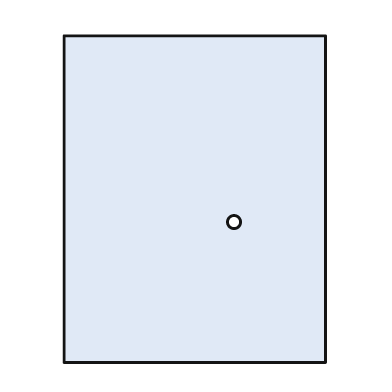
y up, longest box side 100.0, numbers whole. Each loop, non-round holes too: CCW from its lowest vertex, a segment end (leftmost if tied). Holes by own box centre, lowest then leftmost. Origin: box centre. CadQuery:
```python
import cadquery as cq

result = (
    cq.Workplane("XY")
    .moveTo(-40.0, -50.0)
    .lineTo(40.0, -50.0)
    .lineTo(40.0, 50.0)
    .lineTo(-40.0, 50.0)
    .close()
    .moveTo(12.0, -7.0)
    .circle(2.0)
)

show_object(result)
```